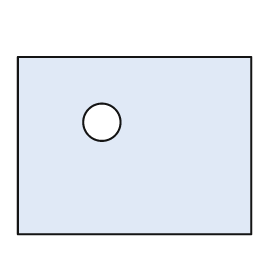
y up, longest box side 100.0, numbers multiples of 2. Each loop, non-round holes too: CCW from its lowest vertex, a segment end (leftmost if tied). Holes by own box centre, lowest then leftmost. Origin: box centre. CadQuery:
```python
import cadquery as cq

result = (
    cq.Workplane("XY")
    .moveTo(-50.0, -38.0)
    .lineTo(50.0, -38.0)
    .lineTo(50.0, 38.0)
    .lineTo(-50.0, 38.0)
    .close()
    .moveTo(-14.0, 10.0)
    .circle(8.0)
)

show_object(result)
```